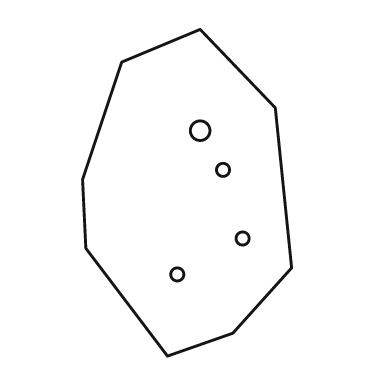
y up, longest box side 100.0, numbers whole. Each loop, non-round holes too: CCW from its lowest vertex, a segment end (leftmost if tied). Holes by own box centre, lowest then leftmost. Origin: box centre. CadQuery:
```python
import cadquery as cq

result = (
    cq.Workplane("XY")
    .moveTo(-6.0, -50.0)
    .lineTo(14.0, -43.0)
    .lineTo(32.0, -23.0)
    .lineTo(27.0, 26.0)
    .lineTo(4.0, 50.0)
    .lineTo(-20.0, 40.0)
    .lineTo(-32.0, 4.0)
    .lineTo(-31.0, -17.0)
    .close()
    .moveTo(-3.0, -25.0)
    .circle(2.0)
    .moveTo(17.0, -14.0)
    .circle(2.0)
    .moveTo(11.0, 7.0)
    .circle(2.0)
    .moveTo(4.0, 19.0)
    .circle(3.0)
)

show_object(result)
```